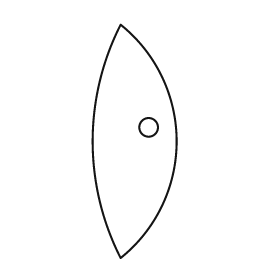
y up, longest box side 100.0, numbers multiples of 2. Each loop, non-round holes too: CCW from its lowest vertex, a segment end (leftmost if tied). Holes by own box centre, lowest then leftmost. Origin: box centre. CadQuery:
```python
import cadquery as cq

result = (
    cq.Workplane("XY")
    .moveTo(-6.0, -50.0)
    .threePointArc((18.0, 0.0), (-6.0, 50.0))
    .threePointArc((-18.0, 0.0), (-6.0, -50.0))
    .close()
    .moveTo(6.0, 6.0)
    .circle(4.0)
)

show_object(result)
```